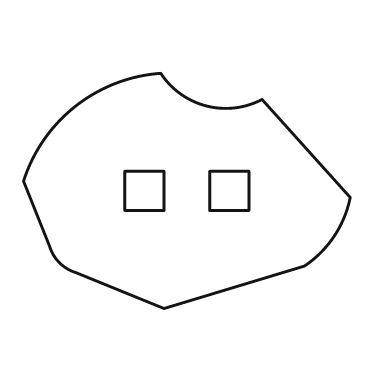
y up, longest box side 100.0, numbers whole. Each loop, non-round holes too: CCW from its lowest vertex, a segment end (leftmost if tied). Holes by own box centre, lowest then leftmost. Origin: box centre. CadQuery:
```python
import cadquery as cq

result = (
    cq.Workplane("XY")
    .moveTo(-7.0, -36.0)
    .lineTo(36.0, -23.0)
    .threePointArc((45.0, -14.0), (50.0, -2.0))
    .lineTo(23.0, 28.0)
    .threePointArc((6.0, 26.0), (-8.0, 36.0))
    .threePointArc((-34.0, 26.0), (-50.0, 3.0))
    .lineTo(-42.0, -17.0)
    .threePointArc((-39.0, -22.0), (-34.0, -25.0))
    .close()
    .moveTo(-19.0, -6.0)
    .lineTo(-7.0, -6.0)
    .lineTo(-7.0, 6.0)
    .lineTo(-19.0, 6.0)
    .close()
    .moveTo(7.0, -6.0)
    .lineTo(19.0, -6.0)
    .lineTo(19.0, 6.0)
    .lineTo(7.0, 6.0)
    .close()
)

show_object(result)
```